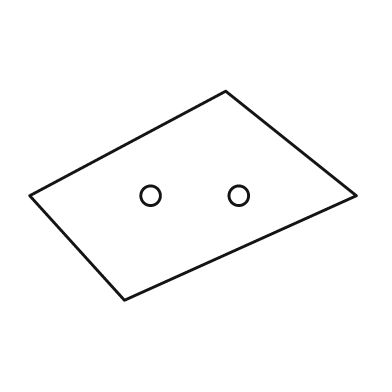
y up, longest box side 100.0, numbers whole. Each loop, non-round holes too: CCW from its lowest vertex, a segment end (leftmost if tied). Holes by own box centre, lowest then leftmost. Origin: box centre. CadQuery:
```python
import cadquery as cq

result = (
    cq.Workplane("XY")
    .moveTo(-21.0, -32.0)
    .lineTo(50.0, 0.0)
    .lineTo(10.0, 32.0)
    .lineTo(-50.0, 0.0)
    .close()
    .moveTo(-13.0, 0.0)
    .circle(3.0)
    .moveTo(14.0, 0.0)
    .circle(3.0)
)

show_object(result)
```